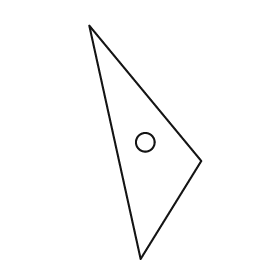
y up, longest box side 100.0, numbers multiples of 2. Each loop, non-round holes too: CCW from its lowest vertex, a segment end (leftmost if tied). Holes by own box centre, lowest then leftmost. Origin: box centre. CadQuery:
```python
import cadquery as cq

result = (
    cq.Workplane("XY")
    .moveTo(-2.0, -50.0)
    .lineTo(24.0, -8.0)
    .lineTo(-24.0, 50.0)
    .close()
    .moveTo(0.0, 0.0)
    .circle(4.0)
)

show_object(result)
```